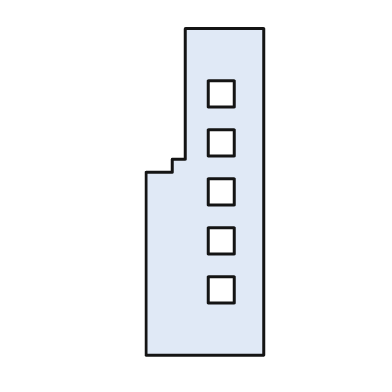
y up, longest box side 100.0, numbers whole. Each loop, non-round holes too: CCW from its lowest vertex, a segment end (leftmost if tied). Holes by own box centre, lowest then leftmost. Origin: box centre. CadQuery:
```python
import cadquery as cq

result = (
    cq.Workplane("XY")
    .moveTo(-18.0, -50.0)
    .lineTo(18.0, -50.0)
    .lineTo(18.0, 50.0)
    .lineTo(-6.0, 50.0)
    .lineTo(-6.0, 10.0)
    .lineTo(-10.0, 10.0)
    .lineTo(-10.0, 6.0)
    .lineTo(-18.0, 6.0)
    .close()
    .moveTo(1.0, -34.0)
    .lineTo(9.0, -34.0)
    .lineTo(9.0, -26.0)
    .lineTo(1.0, -26.0)
    .close()
    .moveTo(1.0, -19.0)
    .lineTo(9.0, -19.0)
    .lineTo(9.0, -11.0)
    .lineTo(1.0, -11.0)
    .close()
    .moveTo(1.0, -4.0)
    .lineTo(9.0, -4.0)
    .lineTo(9.0, 4.0)
    .lineTo(1.0, 4.0)
    .close()
    .moveTo(1.0, 11.0)
    .lineTo(9.0, 11.0)
    .lineTo(9.0, 19.0)
    .lineTo(1.0, 19.0)
    .close()
    .moveTo(1.0, 26.0)
    .lineTo(9.0, 26.0)
    .lineTo(9.0, 34.0)
    .lineTo(1.0, 34.0)
    .close()
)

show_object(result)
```